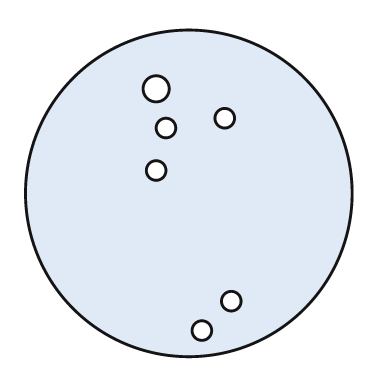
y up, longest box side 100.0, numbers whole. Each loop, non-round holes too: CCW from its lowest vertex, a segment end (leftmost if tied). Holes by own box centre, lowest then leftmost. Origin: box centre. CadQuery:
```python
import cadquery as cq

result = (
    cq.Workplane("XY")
    .moveTo(0.0, 0.0)
    .circle(50.0)
    .moveTo(4.0, -42.0)
    .circle(3.0)
    .moveTo(13.0, -33.0)
    .circle(3.0)
    .moveTo(-10.0, 7.0)
    .circle(3.0)
    .moveTo(-7.0, 20.0)
    .circle(3.0)
    .moveTo(11.0, 23.0)
    .circle(3.0)
    .moveTo(-10.0, 32.0)
    .circle(4.0)
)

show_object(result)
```